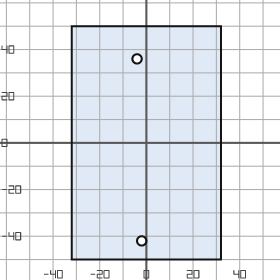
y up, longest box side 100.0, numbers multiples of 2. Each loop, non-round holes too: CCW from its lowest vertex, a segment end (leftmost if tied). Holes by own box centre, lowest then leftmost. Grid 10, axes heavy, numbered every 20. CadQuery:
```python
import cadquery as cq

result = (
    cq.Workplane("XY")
    .moveTo(-32.0, -50.0)
    .lineTo(32.0, -50.0)
    .lineTo(32.0, 50.0)
    .lineTo(-32.0, 50.0)
    .close()
    .moveTo(-2.0, -42.0)
    .circle(2.0)
    .moveTo(-4.0, 36.0)
    .circle(2.0)
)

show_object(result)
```